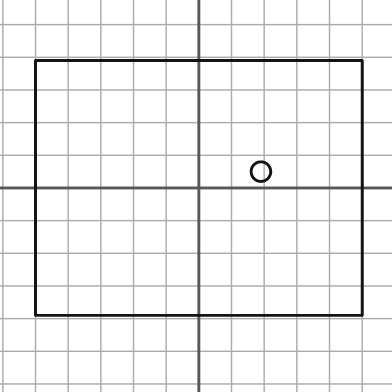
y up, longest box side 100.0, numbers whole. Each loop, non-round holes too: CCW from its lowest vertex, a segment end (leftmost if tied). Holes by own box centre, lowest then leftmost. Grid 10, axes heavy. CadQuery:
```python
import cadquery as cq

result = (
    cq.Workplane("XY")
    .moveTo(-50.0, -39.0)
    .lineTo(50.0, -39.0)
    .lineTo(50.0, 39.0)
    .lineTo(-50.0, 39.0)
    .close()
    .moveTo(19.0, 5.0)
    .circle(3.0)
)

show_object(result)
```